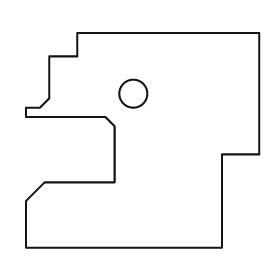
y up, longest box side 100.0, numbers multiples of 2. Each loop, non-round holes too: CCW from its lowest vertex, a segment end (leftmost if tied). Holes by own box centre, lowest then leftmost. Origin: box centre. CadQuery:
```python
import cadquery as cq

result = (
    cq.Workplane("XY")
    .moveTo(-50.0, -46.0)
    .lineTo(34.0, -46.0)
    .lineTo(34.0, -6.0)
    .lineTo(50.0, -6.0)
    .lineTo(50.0, 46.0)
    .lineTo(-28.0, 46.0)
    .lineTo(-28.0, 36.0)
    .lineTo(-40.0, 36.0)
    .lineTo(-40.0, 18.0)
    .lineTo(-44.0, 14.0)
    .lineTo(-50.0, 14.0)
    .lineTo(-50.0, 10.0)
    .lineTo(-16.0, 10.0)
    .lineTo(-12.0, 6.0)
    .lineTo(-12.0, -18.0)
    .lineTo(-42.0, -18.0)
    .lineTo(-50.0, -26.0)
    .close()
    .moveTo(-4.0, 20.0)
    .circle(6.0)
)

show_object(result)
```